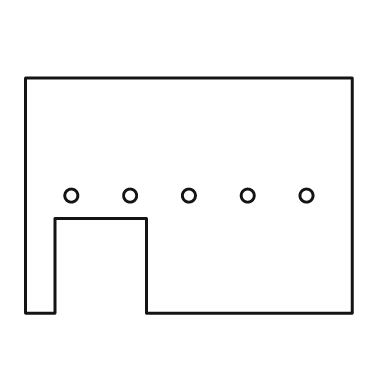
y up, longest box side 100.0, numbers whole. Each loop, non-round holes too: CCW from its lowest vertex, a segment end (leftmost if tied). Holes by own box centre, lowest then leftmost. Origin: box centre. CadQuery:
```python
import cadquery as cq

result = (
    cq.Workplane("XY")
    .moveTo(-50.0, -36.0)
    .lineTo(-41.0, -36.0)
    .lineTo(-41.0, -7.0)
    .lineTo(-13.0, -7.0)
    .lineTo(-13.0, -36.0)
    .lineTo(50.0, -36.0)
    .lineTo(50.0, 36.0)
    .lineTo(-50.0, 36.0)
    .close()
    .moveTo(-36.0, 0.0)
    .circle(2.0)
    .moveTo(-18.0, 0.0)
    .circle(2.0)
    .moveTo(0.0, 0.0)
    .circle(2.0)
    .moveTo(18.0, 0.0)
    .circle(2.0)
    .moveTo(36.0, 0.0)
    .circle(2.0)
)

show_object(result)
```